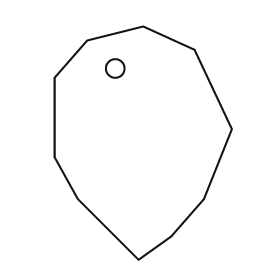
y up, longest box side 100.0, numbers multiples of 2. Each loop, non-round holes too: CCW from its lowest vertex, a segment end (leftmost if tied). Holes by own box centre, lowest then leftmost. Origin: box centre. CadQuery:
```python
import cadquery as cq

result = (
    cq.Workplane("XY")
    .moveTo(-2.0, -50.0)
    .lineTo(12.0, -40.0)
    .lineTo(26.0, -24.0)
    .lineTo(38.0, 6.0)
    .lineTo(22.0, 40.0)
    .lineTo(0.0, 50.0)
    .lineTo(-24.0, 44.0)
    .lineTo(-38.0, 28.0)
    .lineTo(-38.0, -6.0)
    .lineTo(-28.0, -24.0)
    .close()
    .moveTo(-12.0, 32.0)
    .circle(4.0)
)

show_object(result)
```